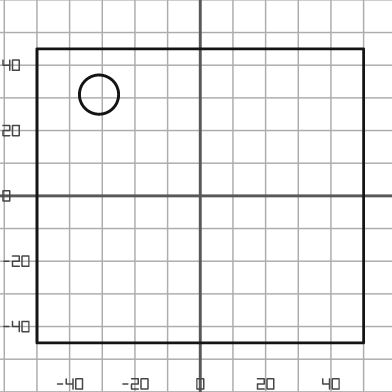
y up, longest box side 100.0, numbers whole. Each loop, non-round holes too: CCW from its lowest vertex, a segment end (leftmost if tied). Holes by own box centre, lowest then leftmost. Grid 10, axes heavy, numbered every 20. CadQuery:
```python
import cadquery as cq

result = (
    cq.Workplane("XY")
    .moveTo(-50.0, -45.0)
    .lineTo(50.0, -45.0)
    .lineTo(50.0, 45.0)
    .lineTo(-50.0, 45.0)
    .close()
    .moveTo(-31.0, 31.0)
    .circle(6.0)
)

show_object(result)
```